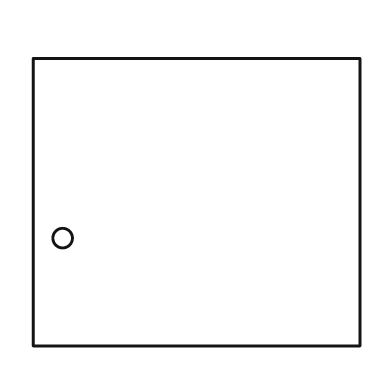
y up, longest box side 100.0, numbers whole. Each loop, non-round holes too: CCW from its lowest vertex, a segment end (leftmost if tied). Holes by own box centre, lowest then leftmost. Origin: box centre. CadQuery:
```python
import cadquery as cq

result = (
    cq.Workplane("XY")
    .moveTo(-50.0, -44.0)
    .lineTo(50.0, -44.0)
    .lineTo(50.0, 44.0)
    .lineTo(-50.0, 44.0)
    .close()
    .moveTo(-41.0, -11.0)
    .circle(3.0)
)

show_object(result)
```